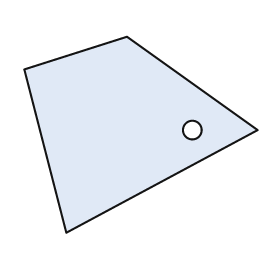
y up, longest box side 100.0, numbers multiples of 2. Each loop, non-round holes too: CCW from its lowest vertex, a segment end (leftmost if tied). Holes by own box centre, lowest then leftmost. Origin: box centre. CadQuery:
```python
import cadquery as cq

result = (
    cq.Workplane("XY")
    .moveTo(-32.0, -42.0)
    .lineTo(50.0, 2.0)
    .lineTo(-6.0, 42.0)
    .lineTo(-50.0, 28.0)
    .close()
    .moveTo(22.0, 2.0)
    .circle(4.0)
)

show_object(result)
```